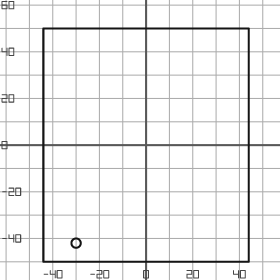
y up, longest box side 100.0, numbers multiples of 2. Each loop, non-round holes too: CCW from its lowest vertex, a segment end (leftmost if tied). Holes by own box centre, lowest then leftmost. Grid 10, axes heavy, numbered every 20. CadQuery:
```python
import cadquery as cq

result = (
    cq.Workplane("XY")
    .moveTo(-44.0, -50.0)
    .lineTo(44.0, -50.0)
    .lineTo(44.0, 50.0)
    .lineTo(-44.0, 50.0)
    .close()
    .moveTo(-30.0, -42.0)
    .circle(2.0)
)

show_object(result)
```